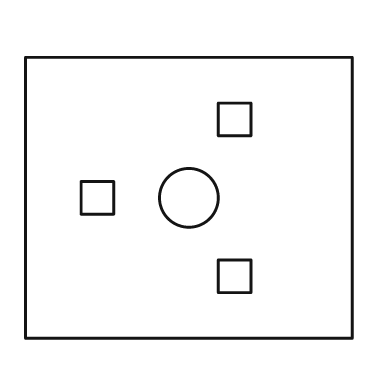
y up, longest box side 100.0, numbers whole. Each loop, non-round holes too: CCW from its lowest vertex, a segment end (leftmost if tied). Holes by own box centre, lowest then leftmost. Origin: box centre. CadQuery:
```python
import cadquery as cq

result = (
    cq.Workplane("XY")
    .moveTo(-50.0, -43.0)
    .lineTo(50.0, -43.0)
    .lineTo(50.0, 43.0)
    .lineTo(-50.0, 43.0)
    .close()
    .moveTo(9.0, -29.0)
    .lineTo(19.0, -29.0)
    .lineTo(19.0, -19.0)
    .lineTo(9.0, -19.0)
    .close()
    .moveTo(-33.0, -5.0)
    .lineTo(-23.0, -5.0)
    .lineTo(-23.0, 5.0)
    .lineTo(-33.0, 5.0)
    .close()
    .moveTo(0.0, 0.0)
    .circle(9.0)
    .moveTo(9.0, 19.0)
    .lineTo(19.0, 19.0)
    .lineTo(19.0, 29.0)
    .lineTo(9.0, 29.0)
    .close()
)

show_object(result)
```